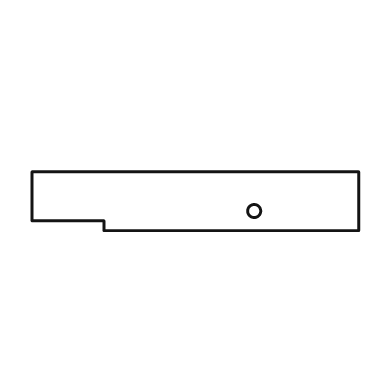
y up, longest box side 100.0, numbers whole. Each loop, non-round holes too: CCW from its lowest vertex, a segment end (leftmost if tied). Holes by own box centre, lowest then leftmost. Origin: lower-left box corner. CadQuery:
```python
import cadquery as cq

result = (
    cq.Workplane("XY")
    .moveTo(22.0, 0.0)
    .lineTo(100.0, 0.0)
    .lineTo(100.0, 18.0)
    .lineTo(0.0, 18.0)
    .lineTo(0.0, 3.0)
    .lineTo(22.0, 3.0)
    .close()
    .moveTo(68.0, 6.0)
    .circle(2.0)
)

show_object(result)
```